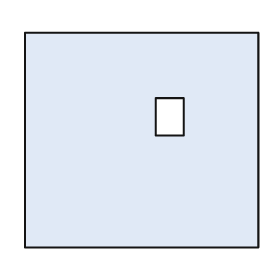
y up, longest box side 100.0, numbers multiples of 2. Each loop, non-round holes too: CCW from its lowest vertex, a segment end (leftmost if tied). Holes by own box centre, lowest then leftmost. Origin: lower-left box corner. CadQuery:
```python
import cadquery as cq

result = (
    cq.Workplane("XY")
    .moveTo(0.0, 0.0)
    .lineTo(100.0, 0.0)
    .lineTo(100.0, 92.0)
    .lineTo(0.0, 92.0)
    .close()
    .moveTo(56.0, 48.0)
    .lineTo(68.0, 48.0)
    .lineTo(68.0, 64.0)
    .lineTo(56.0, 64.0)
    .close()
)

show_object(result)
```